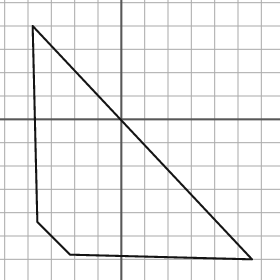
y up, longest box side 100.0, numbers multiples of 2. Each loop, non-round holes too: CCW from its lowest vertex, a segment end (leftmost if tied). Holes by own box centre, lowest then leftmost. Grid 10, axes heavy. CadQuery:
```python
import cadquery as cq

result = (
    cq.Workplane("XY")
    .moveTo(56.0, -60.0)
    .lineTo(-38.0, 40.0)
    .lineTo(-36.0, -44.0)
    .lineTo(-22.0, -58.0)
    .close()
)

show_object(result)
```